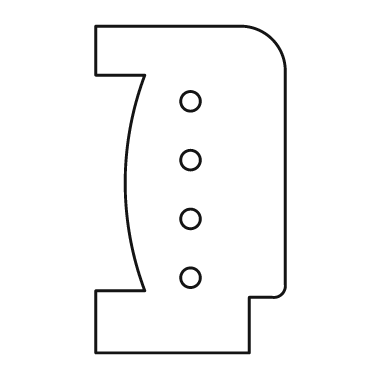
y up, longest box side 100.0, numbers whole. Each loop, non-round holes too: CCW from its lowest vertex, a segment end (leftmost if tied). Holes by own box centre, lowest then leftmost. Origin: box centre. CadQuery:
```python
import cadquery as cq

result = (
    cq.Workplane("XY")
    .moveTo(-29.0, -50.0)
    .lineTo(18.0, -50.0)
    .lineTo(18.0, -33.0)
    .lineTo(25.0, -33.0)
    .threePointArc((28.0, -32.0), (29.0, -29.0))
    .lineTo(29.0, 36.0)
    .threePointArc((25.0, 46.0), (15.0, 50.0))
    .lineTo(-29.0, 50.0)
    .lineTo(-29.0, 35.0)
    .lineTo(-14.0, 35.0)
    .threePointArc((-20.0, 2.0), (-14.0, -31.0))
    .lineTo(-29.0, -31.0)
    .close()
    .moveTo(0.0, -27.0)
    .circle(3.0)
    .moveTo(0.0, -9.0)
    .circle(3.0)
    .moveTo(0.0, 9.0)
    .circle(3.0)
    .moveTo(0.0, 27.0)
    .circle(3.0)
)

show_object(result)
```